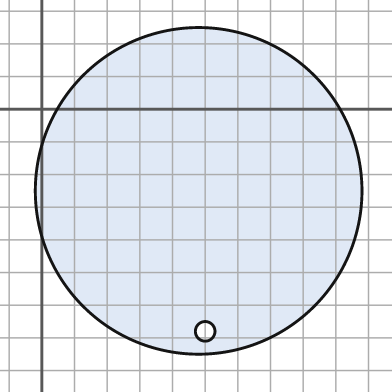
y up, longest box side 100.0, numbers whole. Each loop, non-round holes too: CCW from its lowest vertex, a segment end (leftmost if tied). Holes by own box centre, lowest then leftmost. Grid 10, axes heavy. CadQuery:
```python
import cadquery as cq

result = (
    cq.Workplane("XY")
    .moveTo(48.0, -25.0)
    .circle(50.0)
    .moveTo(50.0, -68.0)
    .circle(3.0)
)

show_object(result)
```